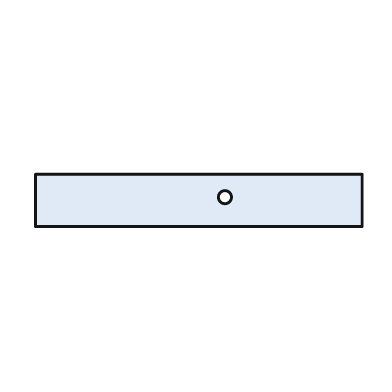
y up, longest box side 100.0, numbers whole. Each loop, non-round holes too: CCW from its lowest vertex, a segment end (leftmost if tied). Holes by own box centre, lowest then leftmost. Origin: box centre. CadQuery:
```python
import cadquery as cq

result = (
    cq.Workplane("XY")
    .moveTo(-50.0, -8.0)
    .lineTo(50.0, -8.0)
    .lineTo(50.0, 8.0)
    .lineTo(-50.0, 8.0)
    .close()
    .moveTo(8.0, 1.0)
    .circle(2.0)
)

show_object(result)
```